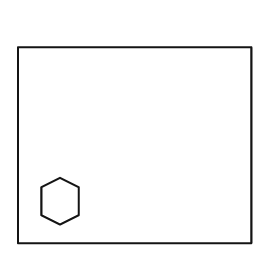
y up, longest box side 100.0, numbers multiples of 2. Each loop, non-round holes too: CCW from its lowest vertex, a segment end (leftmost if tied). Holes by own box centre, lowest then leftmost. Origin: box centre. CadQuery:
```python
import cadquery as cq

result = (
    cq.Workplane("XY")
    .moveTo(-50.0, -42.0)
    .lineTo(50.0, -42.0)
    .lineTo(50.0, 42.0)
    .lineTo(-50.0, 42.0)
    .close()
    .moveTo(-32.0, -34.0)
    .lineTo(-24.0, -30.0)
    .lineTo(-24.0, -18.0)
    .lineTo(-32.0, -14.0)
    .lineTo(-40.0, -18.0)
    .lineTo(-40.0, -30.0)
    .close()
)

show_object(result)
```